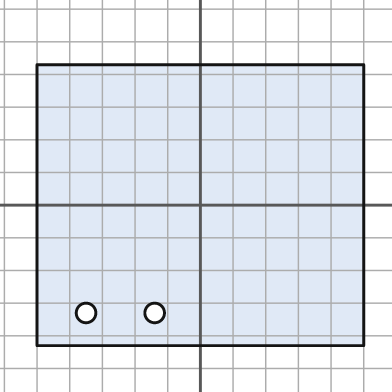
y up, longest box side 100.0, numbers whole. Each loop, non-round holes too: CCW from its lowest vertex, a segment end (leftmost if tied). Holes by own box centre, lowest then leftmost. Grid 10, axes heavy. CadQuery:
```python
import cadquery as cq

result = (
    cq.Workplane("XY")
    .moveTo(-50.0, -43.0)
    .lineTo(50.0, -43.0)
    .lineTo(50.0, 43.0)
    .lineTo(-50.0, 43.0)
    .close()
    .moveTo(-35.0, -33.0)
    .circle(3.0)
    .moveTo(-14.0, -33.0)
    .circle(3.0)
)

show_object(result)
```